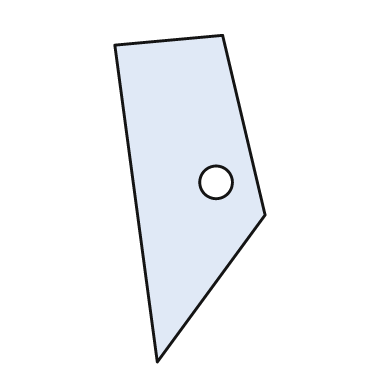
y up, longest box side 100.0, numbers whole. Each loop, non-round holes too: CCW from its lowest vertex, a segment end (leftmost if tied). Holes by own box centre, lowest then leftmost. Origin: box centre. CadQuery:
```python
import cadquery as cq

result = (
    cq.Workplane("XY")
    .moveTo(-10.0, -50.0)
    .lineTo(23.0, -5.0)
    .lineTo(10.0, 50.0)
    .lineTo(-23.0, 47.0)
    .close()
    .moveTo(8.0, 5.0)
    .circle(5.0)
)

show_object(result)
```